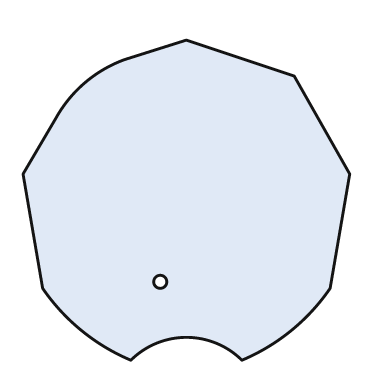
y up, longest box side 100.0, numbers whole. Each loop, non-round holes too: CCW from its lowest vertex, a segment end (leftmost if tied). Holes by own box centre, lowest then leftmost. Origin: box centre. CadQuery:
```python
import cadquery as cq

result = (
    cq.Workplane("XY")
    .moveTo(-17.0, -49.0)
    .threePointArc((0.0, -42.0), (17.0, -49.0))
    .threePointArc((32.0, -40.0), (44.0, -27.0))
    .lineTo(50.0, 8.0)
    .lineTo(33.0, 38.0)
    .lineTo(0.0, 49.0)
    .lineTo(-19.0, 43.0)
    .threePointArc((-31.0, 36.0), (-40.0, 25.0))
    .lineTo(-50.0, 8.0)
    .lineTo(-44.0, -27.0)
    .threePointArc((-32.0, -40.0), (-17.0, -49.0))
    .close()
    .moveTo(-8.0, -25.0)
    .circle(2.0)
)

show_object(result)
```